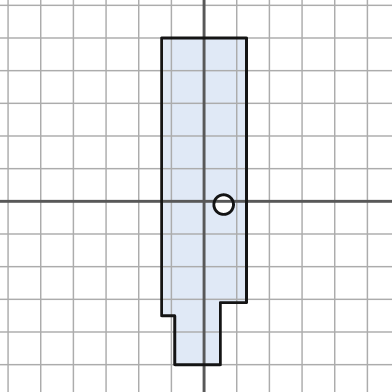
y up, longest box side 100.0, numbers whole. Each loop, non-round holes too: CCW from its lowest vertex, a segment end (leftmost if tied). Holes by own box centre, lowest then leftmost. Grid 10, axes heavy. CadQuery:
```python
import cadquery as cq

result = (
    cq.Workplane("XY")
    .moveTo(-9.0, -50.0)
    .lineTo(5.0, -50.0)
    .lineTo(5.0, -31.0)
    .lineTo(13.0, -31.0)
    .lineTo(13.0, 50.0)
    .lineTo(-13.0, 50.0)
    .lineTo(-13.0, -35.0)
    .lineTo(-9.0, -35.0)
    .close()
    .moveTo(6.0, -1.0)
    .circle(3.0)
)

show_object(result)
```